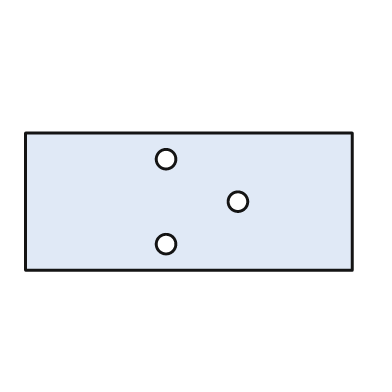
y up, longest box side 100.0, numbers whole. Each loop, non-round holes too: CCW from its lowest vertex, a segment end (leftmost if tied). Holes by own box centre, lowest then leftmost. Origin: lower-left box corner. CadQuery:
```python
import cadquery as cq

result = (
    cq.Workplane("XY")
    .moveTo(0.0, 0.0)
    .lineTo(100.0, 0.0)
    .lineTo(100.0, 42.0)
    .lineTo(0.0, 42.0)
    .close()
    .moveTo(43.0, 8.0)
    .circle(3.0)
    .moveTo(65.0, 21.0)
    .circle(3.0)
    .moveTo(43.0, 34.0)
    .circle(3.0)
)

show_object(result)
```